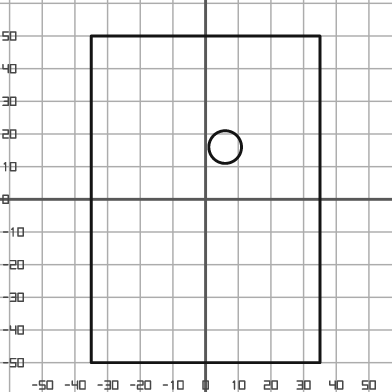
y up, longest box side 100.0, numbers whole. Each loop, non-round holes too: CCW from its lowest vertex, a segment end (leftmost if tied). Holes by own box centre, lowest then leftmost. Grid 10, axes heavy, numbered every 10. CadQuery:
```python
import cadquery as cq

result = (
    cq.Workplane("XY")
    .moveTo(-35.0, -50.0)
    .lineTo(35.0, -50.0)
    .lineTo(35.0, 50.0)
    .lineTo(-35.0, 50.0)
    .close()
    .moveTo(6.0, 16.0)
    .circle(5.0)
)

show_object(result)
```